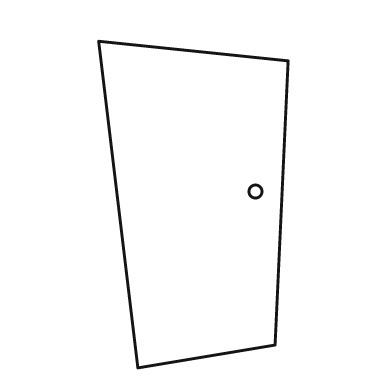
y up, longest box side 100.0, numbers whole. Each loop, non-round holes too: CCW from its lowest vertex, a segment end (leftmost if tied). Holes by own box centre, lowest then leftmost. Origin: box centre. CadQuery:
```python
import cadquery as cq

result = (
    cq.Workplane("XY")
    .moveTo(-17.0, -50.0)
    .lineTo(25.0, -43.0)
    .lineTo(29.0, 44.0)
    .lineTo(-29.0, 50.0)
    .close()
    .moveTo(19.0, 4.0)
    .circle(2.0)
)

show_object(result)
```